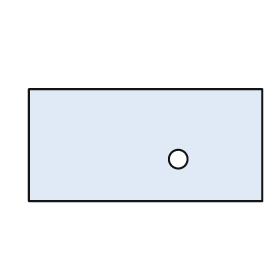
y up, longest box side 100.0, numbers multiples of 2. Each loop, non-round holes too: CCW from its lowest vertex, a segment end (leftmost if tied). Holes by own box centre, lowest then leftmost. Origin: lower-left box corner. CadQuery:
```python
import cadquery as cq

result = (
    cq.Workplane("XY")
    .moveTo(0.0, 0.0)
    .lineTo(100.0, 0.0)
    .lineTo(100.0, 48.0)
    .lineTo(0.0, 48.0)
    .close()
    .moveTo(64.0, 18.0)
    .circle(4.0)
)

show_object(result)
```